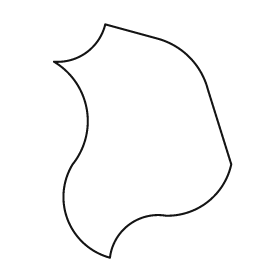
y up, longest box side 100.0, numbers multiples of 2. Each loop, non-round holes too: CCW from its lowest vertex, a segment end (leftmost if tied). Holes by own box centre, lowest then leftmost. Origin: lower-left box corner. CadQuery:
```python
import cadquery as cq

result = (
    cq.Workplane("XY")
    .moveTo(24.0, 0.0)
    .threePointArc((32.0, 14.0), (48.0, 18.0))
    .threePointArc((66.0, 24.0), (76.0, 40.0))
    .lineTo(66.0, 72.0)
    .threePointArc((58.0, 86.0), (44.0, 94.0))
    .lineTo(22.0, 100.0)
    .threePointArc((14.0, 88.0), (0.0, 84.0))
    .threePointArc((14.0, 64.0), (8.0, 40.0))
    .threePointArc((6.0, 16.0), (24.0, 0.0))
    .close()
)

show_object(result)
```